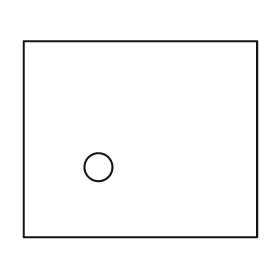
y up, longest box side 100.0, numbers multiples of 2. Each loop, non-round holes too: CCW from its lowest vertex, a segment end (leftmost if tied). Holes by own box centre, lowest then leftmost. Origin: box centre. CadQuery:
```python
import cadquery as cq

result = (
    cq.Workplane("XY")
    .moveTo(-50.0, -42.0)
    .lineTo(50.0, -42.0)
    .lineTo(50.0, 42.0)
    .lineTo(-50.0, 42.0)
    .close()
    .moveTo(-18.0, -12.0)
    .circle(6.0)
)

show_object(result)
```